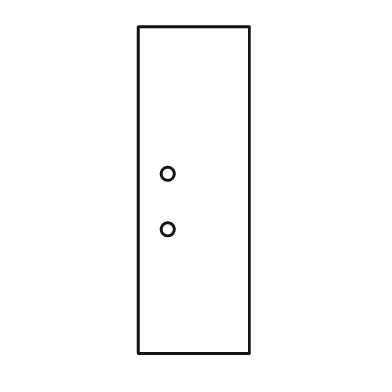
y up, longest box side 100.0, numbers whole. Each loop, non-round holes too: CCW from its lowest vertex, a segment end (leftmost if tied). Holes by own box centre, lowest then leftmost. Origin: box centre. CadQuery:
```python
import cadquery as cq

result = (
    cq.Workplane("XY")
    .moveTo(-17.0, -50.0)
    .lineTo(17.0, -50.0)
    .lineTo(17.0, 50.0)
    .lineTo(-17.0, 50.0)
    .close()
    .moveTo(-8.0, -12.0)
    .circle(2.0)
    .moveTo(-8.0, 5.0)
    .circle(2.0)
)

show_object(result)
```